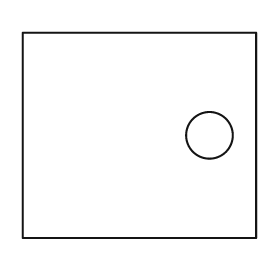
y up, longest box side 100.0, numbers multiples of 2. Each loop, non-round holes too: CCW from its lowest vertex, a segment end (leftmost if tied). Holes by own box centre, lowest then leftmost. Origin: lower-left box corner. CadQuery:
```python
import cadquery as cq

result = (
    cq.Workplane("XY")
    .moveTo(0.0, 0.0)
    .lineTo(100.0, 0.0)
    .lineTo(100.0, 88.0)
    .lineTo(0.0, 88.0)
    .close()
    .moveTo(80.0, 44.0)
    .circle(10.0)
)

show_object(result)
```